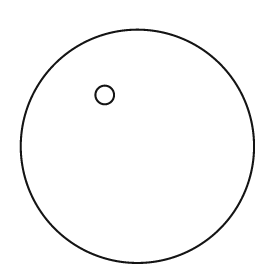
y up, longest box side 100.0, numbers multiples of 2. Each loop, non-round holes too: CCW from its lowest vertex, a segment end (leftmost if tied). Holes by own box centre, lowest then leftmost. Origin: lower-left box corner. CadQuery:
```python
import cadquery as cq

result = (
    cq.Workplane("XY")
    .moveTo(50.0, 50.0)
    .circle(50.0)
    .moveTo(36.0, 72.0)
    .circle(4.0)
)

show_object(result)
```